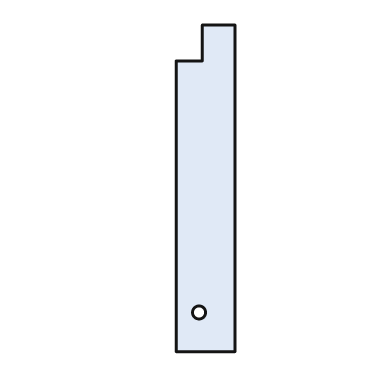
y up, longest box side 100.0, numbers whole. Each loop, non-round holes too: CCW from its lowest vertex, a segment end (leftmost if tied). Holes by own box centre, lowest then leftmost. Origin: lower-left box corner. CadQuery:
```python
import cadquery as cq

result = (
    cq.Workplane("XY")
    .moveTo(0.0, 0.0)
    .lineTo(18.0, 0.0)
    .lineTo(18.0, 100.0)
    .lineTo(8.0, 100.0)
    .lineTo(8.0, 89.0)
    .lineTo(0.0, 89.0)
    .close()
    .moveTo(7.0, 12.0)
    .circle(2.0)
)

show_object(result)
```